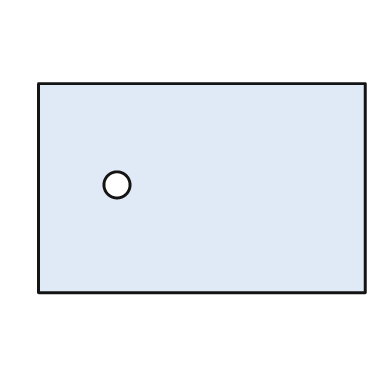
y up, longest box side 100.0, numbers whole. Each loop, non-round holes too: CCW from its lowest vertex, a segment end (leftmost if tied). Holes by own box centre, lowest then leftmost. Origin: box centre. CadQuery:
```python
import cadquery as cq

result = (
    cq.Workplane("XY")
    .moveTo(-50.0, -32.0)
    .lineTo(50.0, -32.0)
    .lineTo(50.0, 32.0)
    .lineTo(-50.0, 32.0)
    .close()
    .moveTo(-26.0, 1.0)
    .circle(4.0)
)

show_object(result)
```